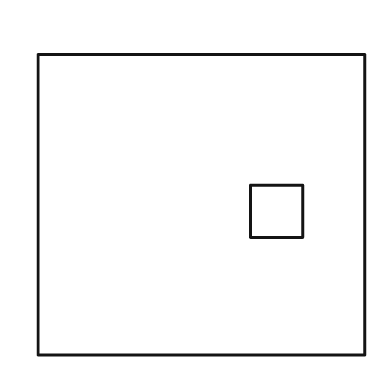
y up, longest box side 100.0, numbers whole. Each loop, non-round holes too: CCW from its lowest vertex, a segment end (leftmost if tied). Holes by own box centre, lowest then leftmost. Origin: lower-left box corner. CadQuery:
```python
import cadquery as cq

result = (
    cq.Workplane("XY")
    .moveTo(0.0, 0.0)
    .lineTo(100.0, 0.0)
    .lineTo(100.0, 92.0)
    .lineTo(0.0, 92.0)
    .close()
    .moveTo(65.0, 36.0)
    .lineTo(81.0, 36.0)
    .lineTo(81.0, 52.0)
    .lineTo(65.0, 52.0)
    .close()
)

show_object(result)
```